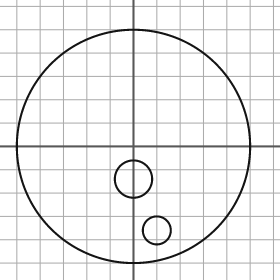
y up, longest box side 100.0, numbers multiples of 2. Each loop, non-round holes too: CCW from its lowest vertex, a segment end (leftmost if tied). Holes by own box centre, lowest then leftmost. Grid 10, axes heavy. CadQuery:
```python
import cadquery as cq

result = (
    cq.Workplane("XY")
    .moveTo(0.0, 0.0)
    .circle(50.0)
    .moveTo(10.0, -36.0)
    .circle(6.0)
    .moveTo(0.0, -14.0)
    .circle(8.0)
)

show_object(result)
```